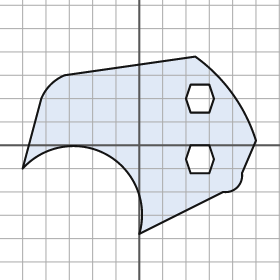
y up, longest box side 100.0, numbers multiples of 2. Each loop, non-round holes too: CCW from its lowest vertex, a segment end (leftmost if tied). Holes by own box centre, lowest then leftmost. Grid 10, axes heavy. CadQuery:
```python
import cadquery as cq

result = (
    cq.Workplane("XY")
    .moveTo(0.0, -38.0)
    .lineTo(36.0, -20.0)
    .threePointArc((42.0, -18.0), (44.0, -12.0))
    .lineTo(50.0, 2.0)
    .threePointArc((40.0, 22.0), (24.0, 38.0))
    .lineTo(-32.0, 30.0)
    .threePointArc((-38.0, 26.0), (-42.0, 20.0))
    .lineTo(-50.0, -10.0)
    .threePointArc((-14.0, -4.0), (0.0, -38.0))
    .close()
    .moveTo(22.0, -12.0)
    .lineTo(30.0, -12.0)
    .lineTo(32.0, -6.0)
    .lineTo(30.0, 0.0)
    .lineTo(22.0, 0.0)
    .lineTo(20.0, -6.0)
    .close()
    .moveTo(22.0, 14.0)
    .lineTo(30.0, 14.0)
    .lineTo(32.0, 20.0)
    .lineTo(30.0, 26.0)
    .lineTo(22.0, 26.0)
    .lineTo(20.0, 20.0)
    .close()
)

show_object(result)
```